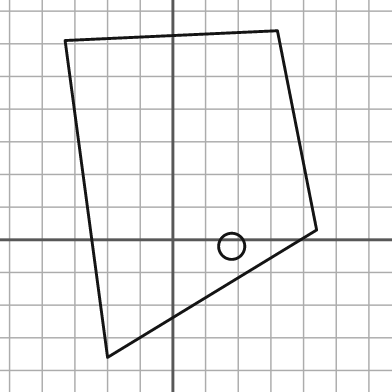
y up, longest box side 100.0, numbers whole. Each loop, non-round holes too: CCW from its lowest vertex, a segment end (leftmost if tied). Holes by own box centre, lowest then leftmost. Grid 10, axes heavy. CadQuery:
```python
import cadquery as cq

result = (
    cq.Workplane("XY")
    .moveTo(-20.0, -36.0)
    .lineTo(44.0, 3.0)
    .lineTo(32.0, 64.0)
    .lineTo(-33.0, 61.0)
    .close()
    .moveTo(18.0, -2.0)
    .circle(4.0)
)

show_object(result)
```